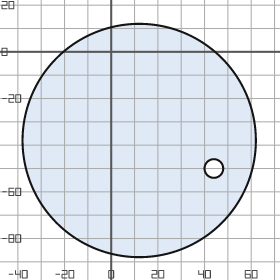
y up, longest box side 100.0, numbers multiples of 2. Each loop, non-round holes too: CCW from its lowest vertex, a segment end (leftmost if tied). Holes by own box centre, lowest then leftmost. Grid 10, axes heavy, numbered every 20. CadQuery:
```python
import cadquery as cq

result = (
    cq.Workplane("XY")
    .moveTo(12.0, -38.0)
    .circle(50.0)
    .moveTo(44.0, -50.0)
    .circle(4.0)
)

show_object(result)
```